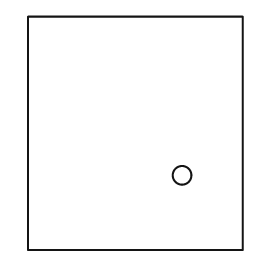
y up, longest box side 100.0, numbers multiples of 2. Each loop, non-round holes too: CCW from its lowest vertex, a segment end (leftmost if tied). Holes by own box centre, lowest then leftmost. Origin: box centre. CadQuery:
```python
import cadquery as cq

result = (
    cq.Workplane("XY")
    .moveTo(-46.0, -50.0)
    .lineTo(46.0, -50.0)
    .lineTo(46.0, 50.0)
    .lineTo(-46.0, 50.0)
    .close()
    .moveTo(20.0, -18.0)
    .circle(4.0)
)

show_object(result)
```